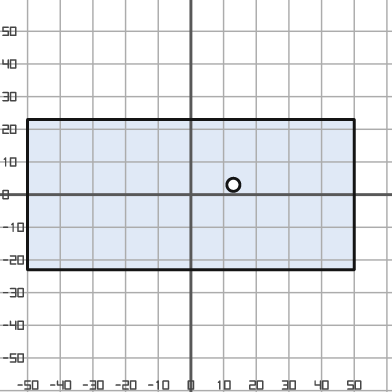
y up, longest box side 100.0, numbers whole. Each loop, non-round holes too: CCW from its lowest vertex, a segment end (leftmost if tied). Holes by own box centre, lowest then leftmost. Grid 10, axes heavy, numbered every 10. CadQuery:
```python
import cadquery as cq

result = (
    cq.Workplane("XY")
    .moveTo(-50.0, -23.0)
    .lineTo(50.0, -23.0)
    .lineTo(50.0, 23.0)
    .lineTo(-50.0, 23.0)
    .close()
    .moveTo(13.0, 3.0)
    .circle(2.0)
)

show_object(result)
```